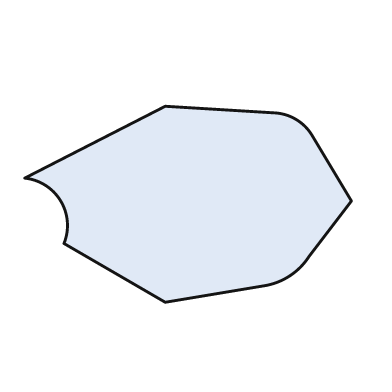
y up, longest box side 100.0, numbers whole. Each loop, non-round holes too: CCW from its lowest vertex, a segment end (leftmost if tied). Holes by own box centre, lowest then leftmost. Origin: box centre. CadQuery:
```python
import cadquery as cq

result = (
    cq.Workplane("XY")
    .moveTo(-7.0, -30.0)
    .lineTo(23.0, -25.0)
    .threePointArc((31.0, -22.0), (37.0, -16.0))
    .lineTo(50.0, 1.0)
    .lineTo(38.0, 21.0)
    .threePointArc((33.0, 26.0), (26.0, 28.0))
    .lineTo(-7.0, 30.0)
    .lineTo(-50.0, 8.0)
    .threePointArc((-39.0, 1.0), (-38.0, -12.0))
    .close()
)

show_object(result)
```